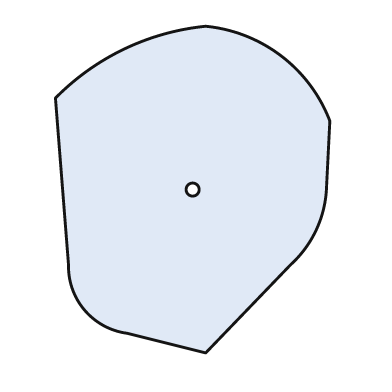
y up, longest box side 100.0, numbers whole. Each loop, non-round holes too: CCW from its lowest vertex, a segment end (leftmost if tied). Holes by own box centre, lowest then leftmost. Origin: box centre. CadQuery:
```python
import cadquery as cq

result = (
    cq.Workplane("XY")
    .moveTo(4.0, -50.0)
    .lineTo(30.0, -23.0)
    .threePointArc((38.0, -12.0), (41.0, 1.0))
    .lineTo(42.0, 21.0)
    .threePointArc((27.0, 41.0), (4.0, 50.0))
    .threePointArc((-21.0, 43.0), (-42.0, 28.0))
    .lineTo(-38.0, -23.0)
    .threePointArc((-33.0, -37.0), (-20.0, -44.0))
    .close()
    .moveTo(0.0, 0.0)
    .circle(2.0)
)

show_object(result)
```